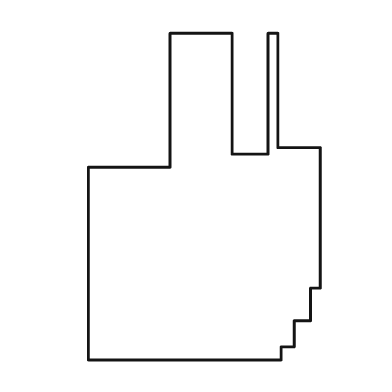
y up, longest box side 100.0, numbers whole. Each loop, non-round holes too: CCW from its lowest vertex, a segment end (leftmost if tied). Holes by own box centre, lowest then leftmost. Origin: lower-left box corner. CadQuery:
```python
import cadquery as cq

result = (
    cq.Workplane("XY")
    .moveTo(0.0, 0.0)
    .lineTo(59.0, 0.0)
    .lineTo(59.0, 4.0)
    .lineTo(63.0, 4.0)
    .lineTo(63.0, 12.0)
    .lineTo(68.0, 12.0)
    .lineTo(68.0, 22.0)
    .lineTo(71.0, 22.0)
    .lineTo(71.0, 65.0)
    .lineTo(58.0, 65.0)
    .lineTo(58.0, 100.0)
    .lineTo(55.0, 100.0)
    .lineTo(55.0, 63.0)
    .lineTo(44.0, 63.0)
    .lineTo(44.0, 100.0)
    .lineTo(25.0, 100.0)
    .lineTo(25.0, 59.0)
    .lineTo(0.0, 59.0)
    .close()
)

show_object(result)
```